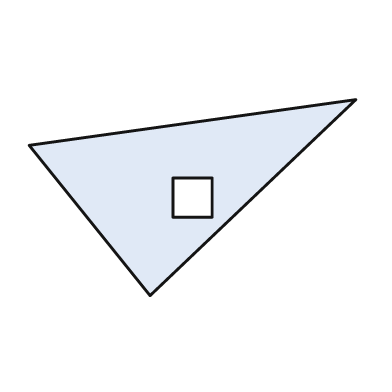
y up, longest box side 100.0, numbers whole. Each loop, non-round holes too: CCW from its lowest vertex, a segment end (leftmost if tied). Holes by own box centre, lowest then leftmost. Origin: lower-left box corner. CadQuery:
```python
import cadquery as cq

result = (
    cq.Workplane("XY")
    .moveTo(37.0, 0.0)
    .lineTo(100.0, 60.0)
    .lineTo(0.0, 46.0)
    .close()
    .moveTo(44.0, 24.0)
    .lineTo(56.0, 24.0)
    .lineTo(56.0, 36.0)
    .lineTo(44.0, 36.0)
    .close()
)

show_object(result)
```